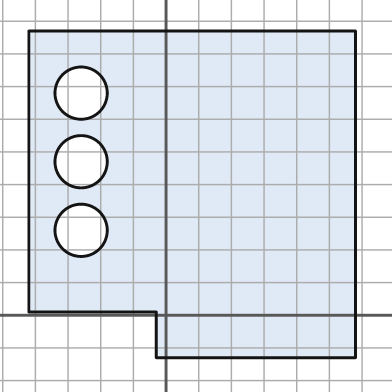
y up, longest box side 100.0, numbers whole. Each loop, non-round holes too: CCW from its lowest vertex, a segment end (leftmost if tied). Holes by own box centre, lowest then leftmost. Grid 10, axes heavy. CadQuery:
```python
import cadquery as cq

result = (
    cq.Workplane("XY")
    .moveTo(-3.0, -13.0)
    .lineTo(58.0, -13.0)
    .lineTo(58.0, 87.0)
    .lineTo(-42.0, 87.0)
    .lineTo(-42.0, 1.0)
    .lineTo(-3.0, 1.0)
    .close()
    .moveTo(-26.0, 26.0)
    .circle(8.0)
    .moveTo(-26.0, 47.0)
    .circle(8.0)
    .moveTo(-26.0, 68.0)
    .circle(8.0)
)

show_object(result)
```